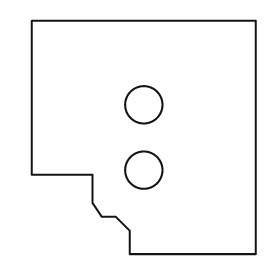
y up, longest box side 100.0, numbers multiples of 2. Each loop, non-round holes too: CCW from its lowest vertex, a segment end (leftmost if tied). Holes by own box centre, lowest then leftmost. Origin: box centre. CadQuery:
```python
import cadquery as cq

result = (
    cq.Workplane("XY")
    .moveTo(-6.0, -50.0)
    .lineTo(48.0, -50.0)
    .lineTo(48.0, 50.0)
    .lineTo(-48.0, 50.0)
    .lineTo(-48.0, -16.0)
    .lineTo(-22.0, -16.0)
    .lineTo(-22.0, -28.0)
    .lineTo(-18.0, -34.0)
    .lineTo(-12.0, -34.0)
    .lineTo(-6.0, -40.0)
    .close()
    .moveTo(0.0, -14.0)
    .circle(8.0)
    .moveTo(0.0, 14.0)
    .circle(8.0)
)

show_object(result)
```